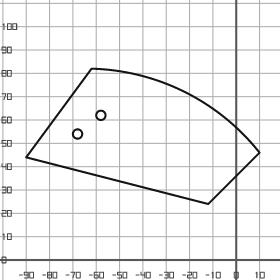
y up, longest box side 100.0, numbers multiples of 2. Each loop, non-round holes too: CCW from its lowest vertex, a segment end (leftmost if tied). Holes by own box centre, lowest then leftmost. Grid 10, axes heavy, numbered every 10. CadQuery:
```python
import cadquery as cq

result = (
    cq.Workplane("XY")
    .moveTo(-12.0, 24.0)
    .lineTo(10.0, 46.0)
    .threePointArc((-22.0, 72.0), (-62.0, 82.0))
    .lineTo(-90.0, 44.0)
    .close()
    .moveTo(-68.0, 54.0)
    .circle(2.0)
    .moveTo(-58.0, 62.0)
    .circle(2.0)
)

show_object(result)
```